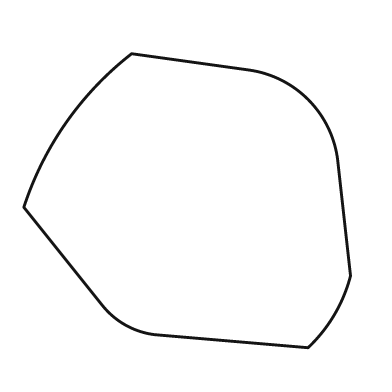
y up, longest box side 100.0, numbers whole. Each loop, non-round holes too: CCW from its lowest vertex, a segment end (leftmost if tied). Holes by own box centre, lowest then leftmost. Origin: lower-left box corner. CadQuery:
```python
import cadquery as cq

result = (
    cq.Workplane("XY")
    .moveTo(87.0, 0.0)
    .threePointArc((95.0, 10.0), (100.0, 22.0))
    .lineTo(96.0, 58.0)
    .threePointArc((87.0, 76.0), (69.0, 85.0))
    .lineTo(33.0, 90.0)
    .threePointArc((13.0, 69.0), (0.0, 43.0))
    .lineTo(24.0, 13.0)
    .threePointArc((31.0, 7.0), (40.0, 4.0))
    .close()
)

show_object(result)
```